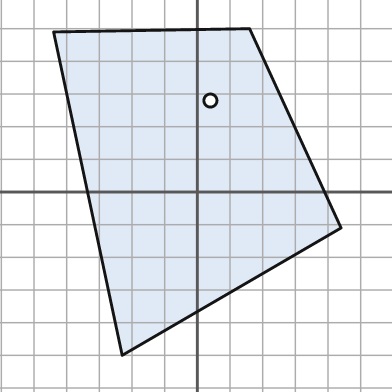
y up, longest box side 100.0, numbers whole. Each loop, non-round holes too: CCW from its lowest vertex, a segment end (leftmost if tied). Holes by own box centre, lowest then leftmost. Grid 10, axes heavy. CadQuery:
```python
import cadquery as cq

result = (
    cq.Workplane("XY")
    .moveTo(-23.0, -50.0)
    .lineTo(44.0, -11.0)
    .lineTo(16.0, 50.0)
    .lineTo(-44.0, 49.0)
    .close()
    .moveTo(4.0, 28.0)
    .circle(2.0)
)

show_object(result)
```